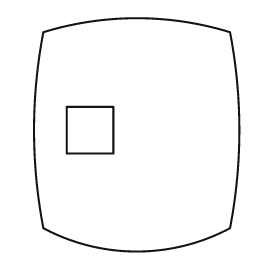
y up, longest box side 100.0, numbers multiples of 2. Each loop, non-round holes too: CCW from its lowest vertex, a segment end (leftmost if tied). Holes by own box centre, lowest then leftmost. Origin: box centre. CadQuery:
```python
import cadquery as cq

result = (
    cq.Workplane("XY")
    .moveTo(-40.0, -40.0)
    .threePointArc((0.0, -50.0), (40.0, -40.0))
    .threePointArc((44.0, 2.0), (40.0, 44.0))
    .threePointArc((0.0, 50.0), (-40.0, 44.0))
    .threePointArc((-44.0, 2.0), (-40.0, -40.0))
    .close()
    .moveTo(-30.0, -8.0)
    .lineTo(-10.0, -8.0)
    .lineTo(-10.0, 12.0)
    .lineTo(-30.0, 12.0)
    .close()
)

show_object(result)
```